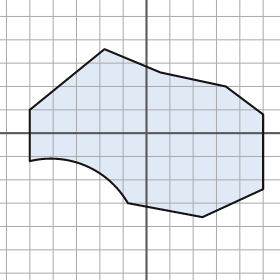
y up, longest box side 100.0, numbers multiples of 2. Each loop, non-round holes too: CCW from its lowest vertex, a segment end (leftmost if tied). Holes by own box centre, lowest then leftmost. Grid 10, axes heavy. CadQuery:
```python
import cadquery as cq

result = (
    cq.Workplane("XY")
    .moveTo(24.0, -36.0)
    .lineTo(50.0, -24.0)
    .lineTo(50.0, 8.0)
    .lineTo(34.0, 20.0)
    .lineTo(6.0, 26.0)
    .lineTo(-18.0, 36.0)
    .lineTo(-50.0, 10.0)
    .lineTo(-50.0, -12.0)
    .threePointArc((-26.0, -14.0), (-8.0, -30.0))
    .close()
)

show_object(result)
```